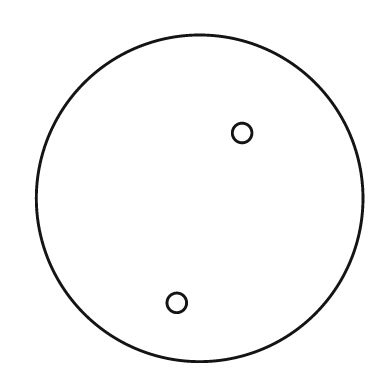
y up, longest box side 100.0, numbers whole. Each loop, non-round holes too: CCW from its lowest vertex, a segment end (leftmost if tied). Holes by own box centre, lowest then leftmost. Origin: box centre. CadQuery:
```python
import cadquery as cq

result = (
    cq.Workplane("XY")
    .moveTo(0.0, 0.0)
    .circle(50.0)
    .moveTo(-7.0, -32.0)
    .circle(3.0)
    .moveTo(13.0, 20.0)
    .circle(3.0)
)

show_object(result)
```